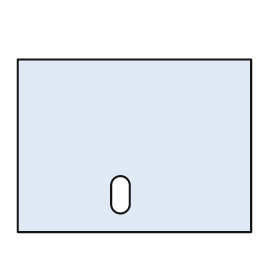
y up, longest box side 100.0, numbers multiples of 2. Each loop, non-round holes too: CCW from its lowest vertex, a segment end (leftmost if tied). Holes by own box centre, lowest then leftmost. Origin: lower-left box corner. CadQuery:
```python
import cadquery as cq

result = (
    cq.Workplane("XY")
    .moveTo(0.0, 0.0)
    .lineTo(100.0, 0.0)
    .lineTo(100.0, 74.0)
    .lineTo(0.0, 74.0)
    .close()
    .moveTo(40.0, 12.0)
    .threePointArc((44.0, 8.0), (48.0, 12.0))
    .lineTo(48.0, 20.0)
    .threePointArc((44.0, 24.0), (40.0, 20.0))
    .close()
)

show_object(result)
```